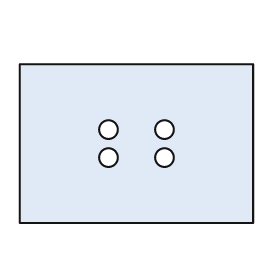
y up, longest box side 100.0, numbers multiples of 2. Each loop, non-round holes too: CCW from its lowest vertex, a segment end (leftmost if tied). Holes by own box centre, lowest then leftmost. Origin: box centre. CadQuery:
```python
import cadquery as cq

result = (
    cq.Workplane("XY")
    .moveTo(-50.0, -34.0)
    .lineTo(50.0, -34.0)
    .lineTo(50.0, 34.0)
    .lineTo(-50.0, 34.0)
    .close()
    .moveTo(-12.0, -6.0)
    .circle(4.0)
    .moveTo(12.0, -6.0)
    .circle(4.0)
    .moveTo(-12.0, 6.0)
    .circle(4.0)
    .moveTo(12.0, 6.0)
    .circle(4.0)
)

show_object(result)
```